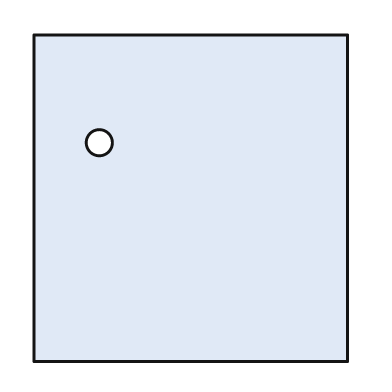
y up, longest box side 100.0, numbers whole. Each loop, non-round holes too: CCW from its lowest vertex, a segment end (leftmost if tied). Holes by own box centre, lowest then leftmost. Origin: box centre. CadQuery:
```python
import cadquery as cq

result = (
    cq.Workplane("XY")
    .moveTo(-48.0, -50.0)
    .lineTo(48.0, -50.0)
    .lineTo(48.0, 50.0)
    .lineTo(-48.0, 50.0)
    .close()
    .moveTo(-28.0, 17.0)
    .circle(4.0)
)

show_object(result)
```